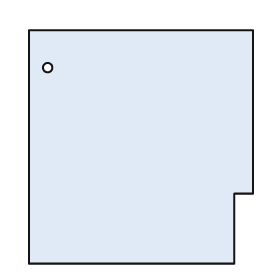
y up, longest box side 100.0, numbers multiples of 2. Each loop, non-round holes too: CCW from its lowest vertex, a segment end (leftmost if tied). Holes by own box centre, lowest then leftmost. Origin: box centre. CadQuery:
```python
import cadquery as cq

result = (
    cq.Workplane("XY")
    .moveTo(-48.0, -50.0)
    .lineTo(40.0, -50.0)
    .lineTo(40.0, -20.0)
    .lineTo(48.0, -20.0)
    .lineTo(48.0, 50.0)
    .lineTo(-48.0, 50.0)
    .close()
    .moveTo(-40.0, 34.0)
    .circle(2.0)
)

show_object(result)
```